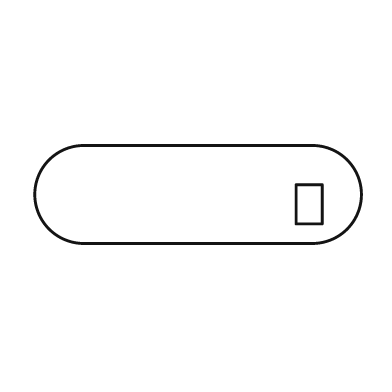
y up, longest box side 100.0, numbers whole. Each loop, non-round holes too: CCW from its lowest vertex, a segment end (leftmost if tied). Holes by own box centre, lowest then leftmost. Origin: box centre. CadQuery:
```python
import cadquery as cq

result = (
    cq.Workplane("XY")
    .moveTo(-35.0, -15.0)
    .lineTo(35.0, -15.0)
    .threePointArc((50.0, 0.0), (35.0, 15.0))
    .lineTo(-35.0, 15.0)
    .threePointArc((-50.0, 0.0), (-35.0, -15.0))
    .close()
    .moveTo(30.0, -9.0)
    .lineTo(38.0, -9.0)
    .lineTo(38.0, 3.0)
    .lineTo(30.0, 3.0)
    .close()
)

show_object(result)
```